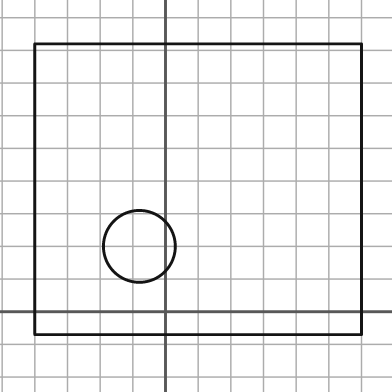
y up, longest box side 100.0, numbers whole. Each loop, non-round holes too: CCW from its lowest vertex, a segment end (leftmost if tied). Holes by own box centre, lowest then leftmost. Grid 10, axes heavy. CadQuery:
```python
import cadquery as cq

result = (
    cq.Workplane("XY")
    .moveTo(-40.0, -7.0)
    .lineTo(60.0, -7.0)
    .lineTo(60.0, 82.0)
    .lineTo(-40.0, 82.0)
    .close()
    .moveTo(-8.0, 20.0)
    .circle(11.0)
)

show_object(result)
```